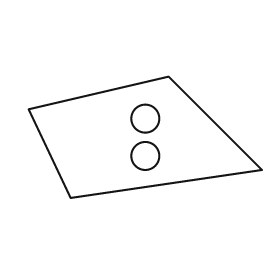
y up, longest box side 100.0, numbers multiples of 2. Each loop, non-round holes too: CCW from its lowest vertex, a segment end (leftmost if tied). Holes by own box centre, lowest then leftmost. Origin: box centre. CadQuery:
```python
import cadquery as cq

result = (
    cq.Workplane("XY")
    .moveTo(-32.0, -26.0)
    .lineTo(50.0, -14.0)
    .lineTo(10.0, 26.0)
    .lineTo(-50.0, 12.0)
    .close()
    .moveTo(0.0, -8.0)
    .circle(6.0)
    .moveTo(0.0, 8.0)
    .circle(6.0)
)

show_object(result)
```